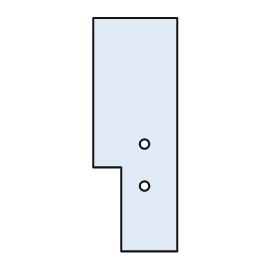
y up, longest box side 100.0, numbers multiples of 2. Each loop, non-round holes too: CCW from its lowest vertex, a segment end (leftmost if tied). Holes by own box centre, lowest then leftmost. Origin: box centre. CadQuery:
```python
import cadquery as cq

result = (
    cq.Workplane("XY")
    .moveTo(-6.0, -50.0)
    .lineTo(18.0, -50.0)
    .lineTo(18.0, 50.0)
    .lineTo(-18.0, 50.0)
    .lineTo(-18.0, -14.0)
    .lineTo(-6.0, -14.0)
    .close()
    .moveTo(4.0, -22.0)
    .circle(2.0)
    .moveTo(4.0, -4.0)
    .circle(2.0)
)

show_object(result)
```